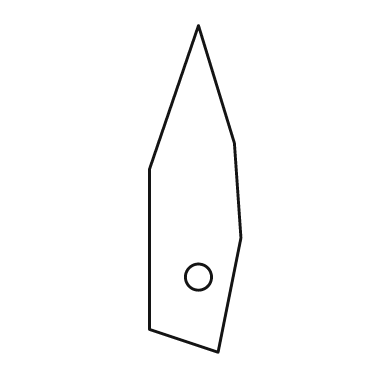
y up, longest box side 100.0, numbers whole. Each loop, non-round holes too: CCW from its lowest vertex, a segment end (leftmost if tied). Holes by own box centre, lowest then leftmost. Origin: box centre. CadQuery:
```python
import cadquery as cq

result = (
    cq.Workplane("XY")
    .moveTo(7.0, -50.0)
    .lineTo(14.0, -15.0)
    .lineTo(12.0, 14.0)
    .lineTo(1.0, 50.0)
    .lineTo(-14.0, 6.0)
    .lineTo(-14.0, -43.0)
    .close()
    .moveTo(1.0, -27.0)
    .circle(4.0)
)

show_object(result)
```